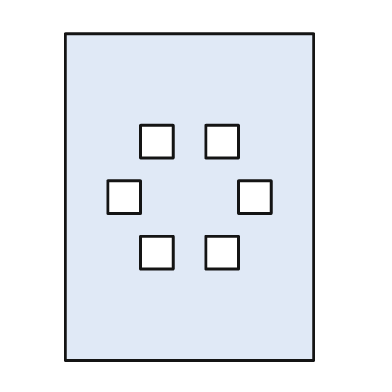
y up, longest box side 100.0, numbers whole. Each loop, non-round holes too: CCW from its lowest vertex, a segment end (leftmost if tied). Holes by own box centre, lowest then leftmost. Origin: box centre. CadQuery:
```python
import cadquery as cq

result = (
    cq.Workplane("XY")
    .moveTo(-38.0, -50.0)
    .lineTo(38.0, -50.0)
    .lineTo(38.0, 50.0)
    .lineTo(-38.0, 50.0)
    .close()
    .moveTo(-15.0, -22.0)
    .lineTo(-5.0, -22.0)
    .lineTo(-5.0, -12.0)
    .lineTo(-15.0, -12.0)
    .close()
    .moveTo(5.0, -22.0)
    .lineTo(15.0, -22.0)
    .lineTo(15.0, -12.0)
    .lineTo(5.0, -12.0)
    .close()
    .moveTo(-25.0, -5.0)
    .lineTo(-15.0, -5.0)
    .lineTo(-15.0, 5.0)
    .lineTo(-25.0, 5.0)
    .close()
    .moveTo(15.0, -5.0)
    .lineTo(25.0, -5.0)
    .lineTo(25.0, 5.0)
    .lineTo(15.0, 5.0)
    .close()
    .moveTo(-15.0, 12.0)
    .lineTo(-5.0, 12.0)
    .lineTo(-5.0, 22.0)
    .lineTo(-15.0, 22.0)
    .close()
    .moveTo(5.0, 12.0)
    .lineTo(15.0, 12.0)
    .lineTo(15.0, 22.0)
    .lineTo(5.0, 22.0)
    .close()
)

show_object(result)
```